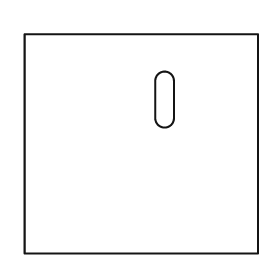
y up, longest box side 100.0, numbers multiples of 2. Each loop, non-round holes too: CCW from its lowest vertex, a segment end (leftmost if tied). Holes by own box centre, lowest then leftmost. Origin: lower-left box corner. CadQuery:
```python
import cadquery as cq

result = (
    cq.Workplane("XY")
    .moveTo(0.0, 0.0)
    .lineTo(100.0, 0.0)
    .lineTo(100.0, 94.0)
    .lineTo(0.0, 94.0)
    .close()
    .moveTo(56.0, 58.0)
    .threePointArc((60.0, 54.0), (64.0, 58.0))
    .lineTo(64.0, 74.0)
    .threePointArc((60.0, 78.0), (56.0, 74.0))
    .close()
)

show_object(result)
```